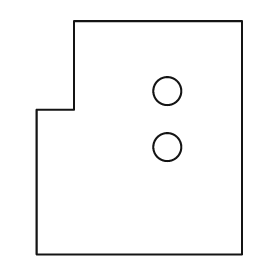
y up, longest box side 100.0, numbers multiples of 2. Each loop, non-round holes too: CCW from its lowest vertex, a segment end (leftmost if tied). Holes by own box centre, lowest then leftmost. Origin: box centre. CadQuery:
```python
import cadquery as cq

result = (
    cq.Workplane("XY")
    .moveTo(-44.0, -50.0)
    .lineTo(44.0, -50.0)
    .lineTo(44.0, 50.0)
    .lineTo(-28.0, 50.0)
    .lineTo(-28.0, 12.0)
    .lineTo(-44.0, 12.0)
    .close()
    .moveTo(12.0, -4.0)
    .circle(6.0)
    .moveTo(12.0, 20.0)
    .circle(6.0)
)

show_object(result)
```